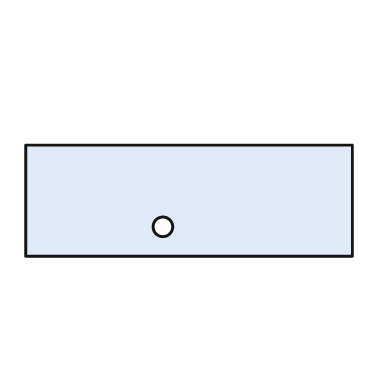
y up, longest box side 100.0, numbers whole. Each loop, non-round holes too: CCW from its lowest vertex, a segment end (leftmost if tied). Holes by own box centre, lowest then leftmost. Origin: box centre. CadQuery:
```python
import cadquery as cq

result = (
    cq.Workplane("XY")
    .moveTo(-50.0, -17.0)
    .lineTo(50.0, -17.0)
    .lineTo(50.0, 17.0)
    .lineTo(-50.0, 17.0)
    .close()
    .moveTo(-8.0, -8.0)
    .circle(3.0)
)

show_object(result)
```